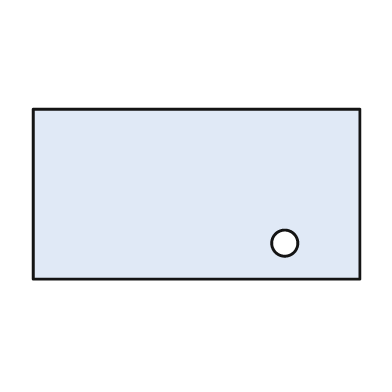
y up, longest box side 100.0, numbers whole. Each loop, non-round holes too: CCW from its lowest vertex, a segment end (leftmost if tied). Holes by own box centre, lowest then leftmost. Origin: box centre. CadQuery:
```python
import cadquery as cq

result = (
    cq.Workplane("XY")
    .moveTo(-50.0, -26.0)
    .lineTo(50.0, -26.0)
    .lineTo(50.0, 26.0)
    .lineTo(-50.0, 26.0)
    .close()
    .moveTo(27.0, -15.0)
    .circle(4.0)
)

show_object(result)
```